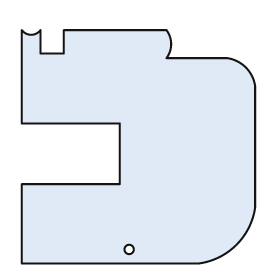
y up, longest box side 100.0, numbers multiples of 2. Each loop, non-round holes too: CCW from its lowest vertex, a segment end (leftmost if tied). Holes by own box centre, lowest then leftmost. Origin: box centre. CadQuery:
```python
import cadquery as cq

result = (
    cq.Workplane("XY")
    .moveTo(-50.0, -50.0)
    .lineTo(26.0, -50.0)
    .threePointArc((42.0, -42.0), (50.0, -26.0))
    .lineTo(50.0, 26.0)
    .threePointArc((46.0, 34.0), (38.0, 38.0))
    .lineTo(12.0, 38.0)
    .threePointArc((14.0, 44.0), (12.0, 50.0))
    .lineTo(-32.0, 50.0)
    .lineTo(-32.0, 40.0)
    .lineTo(-42.0, 40.0)
    .lineTo(-42.0, 50.0)
    .threePointArc((-46.0, 48.0), (-50.0, 50.0))
    .lineTo(-50.0, 10.0)
    .lineTo(-8.0, 10.0)
    .lineTo(-8.0, -16.0)
    .lineTo(-50.0, -16.0)
    .close()
    .moveTo(-4.0, -44.0)
    .circle(2.0)
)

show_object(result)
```